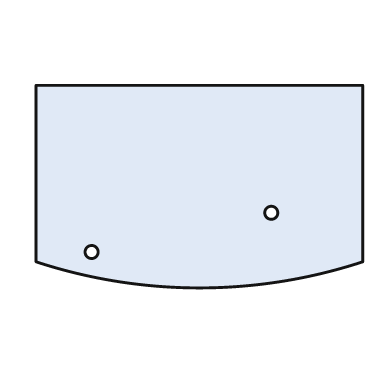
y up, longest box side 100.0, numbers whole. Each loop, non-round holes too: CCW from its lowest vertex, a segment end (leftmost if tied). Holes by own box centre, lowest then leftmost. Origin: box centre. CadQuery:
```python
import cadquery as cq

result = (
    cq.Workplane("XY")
    .moveTo(-50.0, -23.0)
    .threePointArc((0.0, -31.0), (50.0, -23.0))
    .lineTo(50.0, 31.0)
    .lineTo(-50.0, 31.0)
    .close()
    .moveTo(-33.0, -20.0)
    .circle(2.0)
    .moveTo(22.0, -8.0)
    .circle(2.0)
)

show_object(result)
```